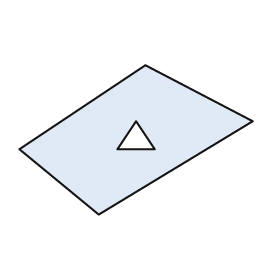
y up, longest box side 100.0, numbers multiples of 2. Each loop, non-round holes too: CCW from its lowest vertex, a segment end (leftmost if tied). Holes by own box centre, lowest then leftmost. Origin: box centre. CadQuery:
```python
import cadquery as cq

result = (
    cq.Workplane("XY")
    .moveTo(-16.0, -32.0)
    .lineTo(50.0, 8.0)
    .lineTo(4.0, 32.0)
    .lineTo(-50.0, -4.0)
    .close()
    .moveTo(-8.0, -4.0)
    .lineTo(8.0, -4.0)
    .lineTo(0.0, 8.0)
    .close()
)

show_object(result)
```